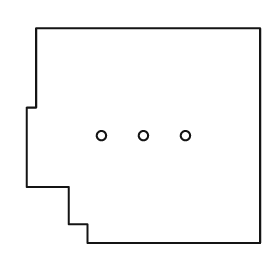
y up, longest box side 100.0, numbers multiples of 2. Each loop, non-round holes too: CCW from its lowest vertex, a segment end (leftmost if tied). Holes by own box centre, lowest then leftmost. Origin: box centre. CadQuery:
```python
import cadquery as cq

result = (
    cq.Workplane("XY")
    .moveTo(-24.0, -46.0)
    .lineTo(50.0, -46.0)
    .lineTo(50.0, 46.0)
    .lineTo(-46.0, 46.0)
    .lineTo(-46.0, 12.0)
    .lineTo(-50.0, 12.0)
    .lineTo(-50.0, -22.0)
    .lineTo(-32.0, -22.0)
    .lineTo(-32.0, -38.0)
    .lineTo(-24.0, -38.0)
    .close()
    .moveTo(-18.0, 0.0)
    .circle(2.0)
    .moveTo(0.0, 0.0)
    .circle(2.0)
    .moveTo(18.0, 0.0)
    .circle(2.0)
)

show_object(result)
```